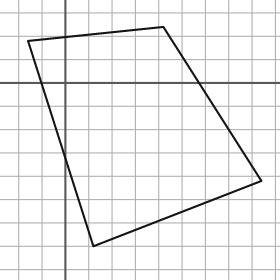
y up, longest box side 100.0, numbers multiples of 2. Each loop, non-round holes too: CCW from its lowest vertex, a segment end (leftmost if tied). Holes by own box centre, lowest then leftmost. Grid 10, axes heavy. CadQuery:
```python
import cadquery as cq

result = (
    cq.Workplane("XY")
    .moveTo(12.0, -70.0)
    .lineTo(84.0, -42.0)
    .lineTo(42.0, 24.0)
    .lineTo(-16.0, 18.0)
    .close()
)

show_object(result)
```